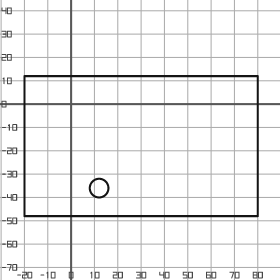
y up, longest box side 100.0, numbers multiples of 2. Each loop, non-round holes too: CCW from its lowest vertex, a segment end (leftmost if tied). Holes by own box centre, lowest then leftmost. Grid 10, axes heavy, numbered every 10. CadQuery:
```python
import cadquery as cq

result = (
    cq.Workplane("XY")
    .moveTo(-20.0, -48.0)
    .lineTo(80.0, -48.0)
    .lineTo(80.0, 12.0)
    .lineTo(-20.0, 12.0)
    .close()
    .moveTo(12.0, -36.0)
    .circle(4.0)
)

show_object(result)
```